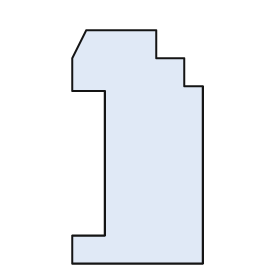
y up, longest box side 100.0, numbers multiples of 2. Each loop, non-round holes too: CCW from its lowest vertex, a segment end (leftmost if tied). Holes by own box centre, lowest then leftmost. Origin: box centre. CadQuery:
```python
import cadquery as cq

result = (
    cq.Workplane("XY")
    .moveTo(-28.0, -50.0)
    .lineTo(28.0, -50.0)
    .lineTo(28.0, 26.0)
    .lineTo(20.0, 26.0)
    .lineTo(20.0, 38.0)
    .lineTo(8.0, 38.0)
    .lineTo(8.0, 50.0)
    .lineTo(-22.0, 50.0)
    .lineTo(-28.0, 38.0)
    .lineTo(-28.0, 24.0)
    .lineTo(-14.0, 24.0)
    .lineTo(-14.0, -38.0)
    .lineTo(-28.0, -38.0)
    .close()
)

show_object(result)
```